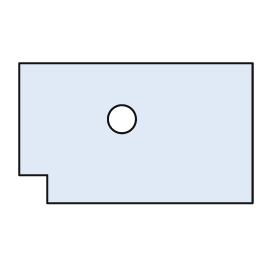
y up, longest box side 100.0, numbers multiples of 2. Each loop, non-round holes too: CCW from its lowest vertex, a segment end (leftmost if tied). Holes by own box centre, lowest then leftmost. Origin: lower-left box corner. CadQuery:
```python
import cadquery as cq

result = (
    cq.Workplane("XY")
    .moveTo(12.0, 0.0)
    .lineTo(100.0, 0.0)
    .lineTo(100.0, 60.0)
    .lineTo(0.0, 60.0)
    .lineTo(0.0, 12.0)
    .lineTo(12.0, 12.0)
    .close()
    .moveTo(44.0, 36.0)
    .circle(6.0)
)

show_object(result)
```